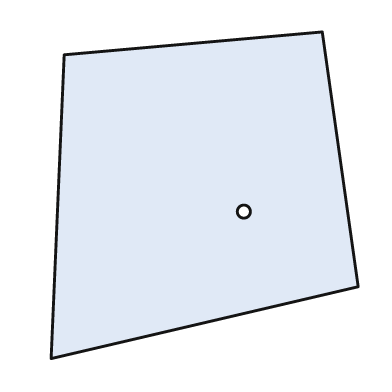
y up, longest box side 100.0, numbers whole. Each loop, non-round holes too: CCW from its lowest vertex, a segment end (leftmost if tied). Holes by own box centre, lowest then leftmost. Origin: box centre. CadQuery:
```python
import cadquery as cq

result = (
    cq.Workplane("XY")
    .moveTo(-47.0, -50.0)
    .lineTo(47.0, -28.0)
    .lineTo(36.0, 50.0)
    .lineTo(-43.0, 43.0)
    .close()
    .moveTo(12.0, -5.0)
    .circle(2.0)
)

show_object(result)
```